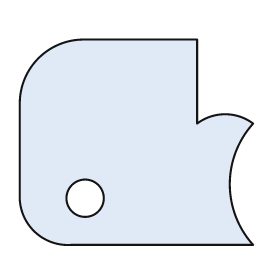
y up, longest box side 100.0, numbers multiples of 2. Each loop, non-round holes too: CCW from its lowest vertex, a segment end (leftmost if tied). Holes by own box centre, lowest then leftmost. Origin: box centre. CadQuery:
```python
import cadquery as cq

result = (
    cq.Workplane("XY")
    .moveTo(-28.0, -44.0)
    .lineTo(50.0, -44.0)
    .threePointArc((40.0, -18.0), (50.0, 8.0))
    .threePointArc((38.0, 12.0), (26.0, 8.0))
    .lineTo(26.0, 44.0)
    .lineTo(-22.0, 44.0)
    .threePointArc((-42.0, 36.0), (-50.0, 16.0))
    .lineTo(-50.0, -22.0)
    .threePointArc((-44.0, -38.0), (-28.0, -44.0))
    .close()
    .moveTo(-22.0, -24.0)
    .circle(8.0)
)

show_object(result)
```